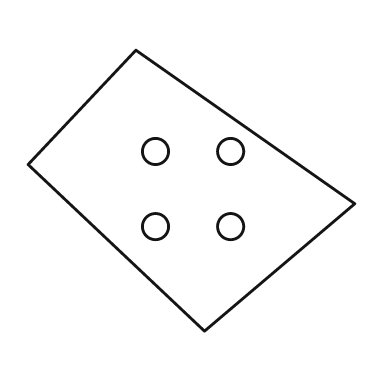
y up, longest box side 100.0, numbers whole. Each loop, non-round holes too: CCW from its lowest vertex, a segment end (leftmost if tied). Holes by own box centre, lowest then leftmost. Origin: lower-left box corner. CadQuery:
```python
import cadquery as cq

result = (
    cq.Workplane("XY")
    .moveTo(54.0, 0.0)
    .lineTo(100.0, 39.0)
    .lineTo(33.0, 86.0)
    .lineTo(0.0, 51.0)
    .close()
    .moveTo(39.0, 32.0)
    .circle(4.0)
    .moveTo(62.0, 32.0)
    .circle(4.0)
    .moveTo(39.0, 55.0)
    .circle(4.0)
    .moveTo(62.0, 55.0)
    .circle(4.0)
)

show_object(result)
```